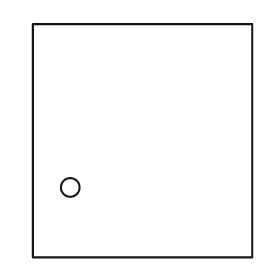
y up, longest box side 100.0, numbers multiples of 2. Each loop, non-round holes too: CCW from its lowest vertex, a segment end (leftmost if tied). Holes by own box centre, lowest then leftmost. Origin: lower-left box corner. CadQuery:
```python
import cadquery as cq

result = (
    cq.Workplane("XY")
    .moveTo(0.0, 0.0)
    .lineTo(94.0, 0.0)
    .lineTo(94.0, 100.0)
    .lineTo(0.0, 100.0)
    .close()
    .moveTo(16.0, 30.0)
    .circle(4.0)
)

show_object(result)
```